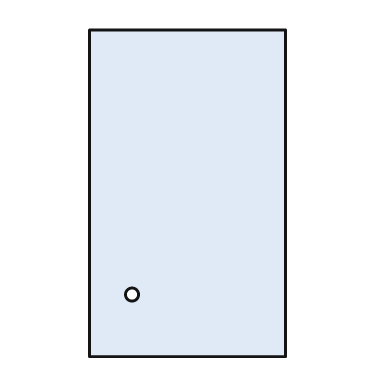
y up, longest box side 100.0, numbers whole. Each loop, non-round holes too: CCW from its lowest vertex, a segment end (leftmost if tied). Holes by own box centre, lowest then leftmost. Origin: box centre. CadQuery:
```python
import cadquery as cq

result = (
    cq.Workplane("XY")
    .moveTo(-30.0, -50.0)
    .lineTo(30.0, -50.0)
    .lineTo(30.0, 50.0)
    .lineTo(-30.0, 50.0)
    .close()
    .moveTo(-17.0, -31.0)
    .circle(2.0)
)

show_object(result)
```